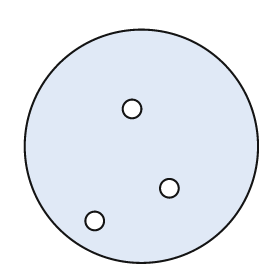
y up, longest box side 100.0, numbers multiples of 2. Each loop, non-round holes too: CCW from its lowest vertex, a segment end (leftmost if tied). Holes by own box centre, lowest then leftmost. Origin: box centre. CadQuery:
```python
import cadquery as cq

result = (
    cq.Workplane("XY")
    .moveTo(0.0, 0.0)
    .circle(50.0)
    .moveTo(-20.0, -32.0)
    .circle(4.0)
    .moveTo(12.0, -18.0)
    .circle(4.0)
    .moveTo(-4.0, 16.0)
    .circle(4.0)
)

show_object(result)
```